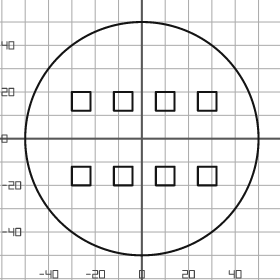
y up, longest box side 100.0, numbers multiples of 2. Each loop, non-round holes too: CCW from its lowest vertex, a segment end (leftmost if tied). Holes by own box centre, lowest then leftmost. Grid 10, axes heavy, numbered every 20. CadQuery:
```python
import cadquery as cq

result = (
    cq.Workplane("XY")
    .moveTo(0.0, 0.0)
    .circle(50.0)
    .moveTo(-30.0, -20.0)
    .lineTo(-22.0, -20.0)
    .lineTo(-22.0, -12.0)
    .lineTo(-30.0, -12.0)
    .close()
    .moveTo(-12.0, -20.0)
    .lineTo(-4.0, -20.0)
    .lineTo(-4.0, -12.0)
    .lineTo(-12.0, -12.0)
    .close()
    .moveTo(6.0, -20.0)
    .lineTo(14.0, -20.0)
    .lineTo(14.0, -12.0)
    .lineTo(6.0, -12.0)
    .close()
    .moveTo(24.0, -20.0)
    .lineTo(32.0, -20.0)
    .lineTo(32.0, -12.0)
    .lineTo(24.0, -12.0)
    .close()
    .moveTo(-30.0, 12.0)
    .lineTo(-22.0, 12.0)
    .lineTo(-22.0, 20.0)
    .lineTo(-30.0, 20.0)
    .close()
    .moveTo(-12.0, 12.0)
    .lineTo(-4.0, 12.0)
    .lineTo(-4.0, 20.0)
    .lineTo(-12.0, 20.0)
    .close()
    .moveTo(6.0, 12.0)
    .lineTo(14.0, 12.0)
    .lineTo(14.0, 20.0)
    .lineTo(6.0, 20.0)
    .close()
    .moveTo(24.0, 12.0)
    .lineTo(32.0, 12.0)
    .lineTo(32.0, 20.0)
    .lineTo(24.0, 20.0)
    .close()
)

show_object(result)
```